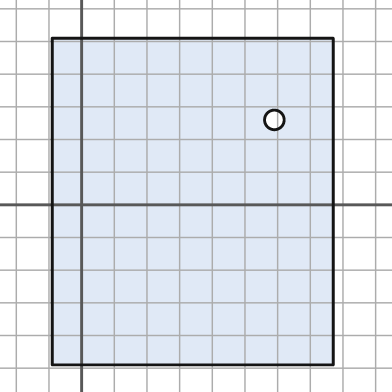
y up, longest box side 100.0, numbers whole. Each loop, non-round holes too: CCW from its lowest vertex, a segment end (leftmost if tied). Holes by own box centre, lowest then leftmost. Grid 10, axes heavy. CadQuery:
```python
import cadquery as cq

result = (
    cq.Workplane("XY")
    .moveTo(-9.0, -49.0)
    .lineTo(77.0, -49.0)
    .lineTo(77.0, 51.0)
    .lineTo(-9.0, 51.0)
    .close()
    .moveTo(59.0, 26.0)
    .circle(3.0)
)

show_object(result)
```